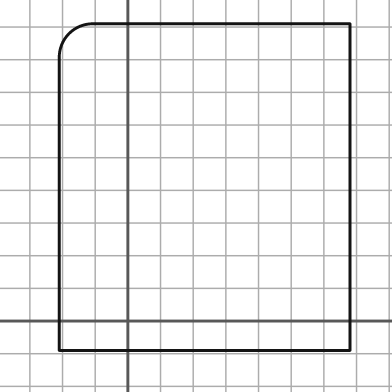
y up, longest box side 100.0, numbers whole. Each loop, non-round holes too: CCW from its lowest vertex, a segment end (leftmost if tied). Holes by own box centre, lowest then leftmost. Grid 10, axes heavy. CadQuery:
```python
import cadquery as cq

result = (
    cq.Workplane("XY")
    .moveTo(-21.0, -9.0)
    .lineTo(68.0, -9.0)
    .lineTo(68.0, 91.0)
    .lineTo(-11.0, 91.0)
    .threePointArc((-18.0, 88.0), (-21.0, 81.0))
    .close()
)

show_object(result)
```